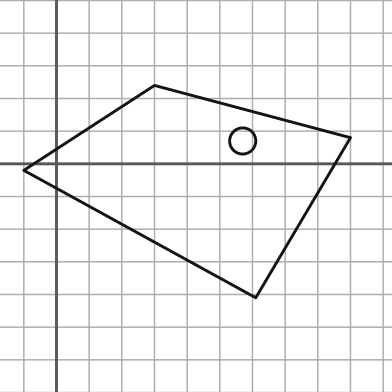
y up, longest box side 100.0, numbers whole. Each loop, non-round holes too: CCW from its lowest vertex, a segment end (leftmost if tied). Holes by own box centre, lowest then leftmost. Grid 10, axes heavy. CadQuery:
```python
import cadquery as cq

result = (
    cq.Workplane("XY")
    .moveTo(61.0, -41.0)
    .lineTo(90.0, 8.0)
    .lineTo(30.0, 24.0)
    .lineTo(-10.0, -2.0)
    .close()
    .moveTo(57.0, 7.0)
    .circle(4.0)
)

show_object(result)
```